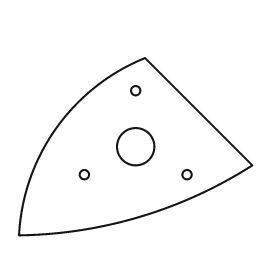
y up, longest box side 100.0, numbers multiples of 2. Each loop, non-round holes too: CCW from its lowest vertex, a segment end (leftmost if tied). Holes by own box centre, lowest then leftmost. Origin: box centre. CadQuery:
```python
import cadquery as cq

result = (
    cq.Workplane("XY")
    .moveTo(-50.0, -38.0)
    .threePointArc((2.0, -30.0), (50.0, -8.0))
    .lineTo(4.0, 38.0)
    .threePointArc((-34.0, 8.0), (-50.0, -38.0))
    .close()
    .moveTo(-22.0, -12.0)
    .circle(2.0)
    .moveTo(22.0, -12.0)
    .circle(2.0)
    .moveTo(0.0, 0.0)
    .circle(8.0)
    .moveTo(0.0, 24.0)
    .circle(2.0)
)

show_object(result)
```